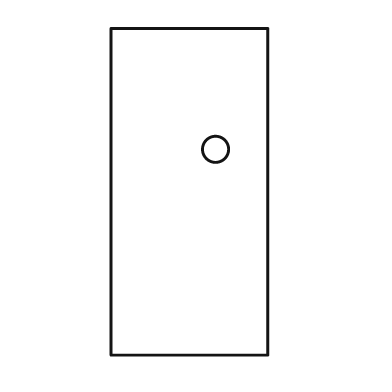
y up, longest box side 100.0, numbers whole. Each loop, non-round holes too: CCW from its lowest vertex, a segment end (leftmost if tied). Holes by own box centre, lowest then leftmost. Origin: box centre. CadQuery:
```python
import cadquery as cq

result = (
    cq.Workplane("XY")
    .moveTo(-24.0, -50.0)
    .lineTo(24.0, -50.0)
    .lineTo(24.0, 50.0)
    .lineTo(-24.0, 50.0)
    .close()
    .moveTo(8.0, 13.0)
    .circle(4.0)
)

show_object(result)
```